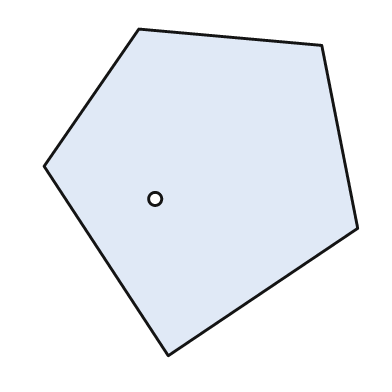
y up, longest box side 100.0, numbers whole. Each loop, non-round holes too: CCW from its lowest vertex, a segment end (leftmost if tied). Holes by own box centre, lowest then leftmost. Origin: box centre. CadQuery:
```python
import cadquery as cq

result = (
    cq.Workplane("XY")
    .moveTo(-10.0, -50.0)
    .lineTo(48.0, -11.0)
    .lineTo(37.0, 45.0)
    .lineTo(-19.0, 50.0)
    .lineTo(-48.0, 8.0)
    .close()
    .moveTo(-14.0, -2.0)
    .circle(2.0)
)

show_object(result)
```